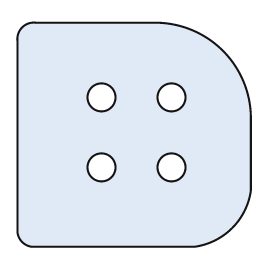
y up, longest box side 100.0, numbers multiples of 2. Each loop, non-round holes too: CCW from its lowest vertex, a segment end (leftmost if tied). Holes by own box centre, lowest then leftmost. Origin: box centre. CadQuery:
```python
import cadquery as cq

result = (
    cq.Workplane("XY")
    .moveTo(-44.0, -48.0)
    .lineTo(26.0, -48.0)
    .threePointArc((42.0, -40.0), (50.0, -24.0))
    .lineTo(50.0, 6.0)
    .threePointArc((38.0, 36.0), (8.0, 48.0))
    .lineTo(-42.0, 48.0)
    .threePointArc((-48.0, 46.0), (-50.0, 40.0))
    .lineTo(-50.0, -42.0)
    .threePointArc((-48.0, -46.0), (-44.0, -48.0))
    .close()
    .moveTo(-14.0, -14.0)
    .circle(6.0)
    .moveTo(16.0, -14.0)
    .circle(6.0)
    .moveTo(-14.0, 16.0)
    .circle(6.0)
    .moveTo(16.0, 16.0)
    .circle(6.0)
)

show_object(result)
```